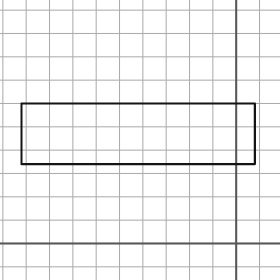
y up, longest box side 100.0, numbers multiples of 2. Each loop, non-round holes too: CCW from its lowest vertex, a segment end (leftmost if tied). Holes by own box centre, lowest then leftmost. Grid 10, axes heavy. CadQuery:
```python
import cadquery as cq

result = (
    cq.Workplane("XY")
    .moveTo(-92.0, 34.0)
    .lineTo(8.0, 34.0)
    .lineTo(8.0, 60.0)
    .lineTo(-92.0, 60.0)
    .close()
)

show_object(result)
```